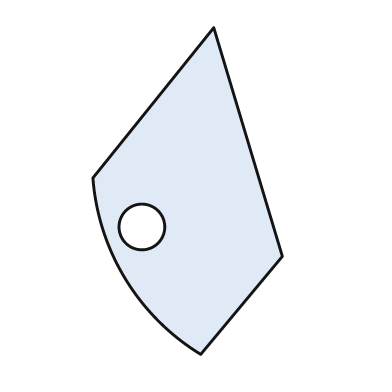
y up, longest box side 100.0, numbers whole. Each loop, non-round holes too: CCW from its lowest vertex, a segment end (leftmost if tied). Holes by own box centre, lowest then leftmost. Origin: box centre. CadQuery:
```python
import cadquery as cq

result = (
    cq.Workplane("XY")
    .moveTo(4.0, -50.0)
    .lineTo(29.0, -20.0)
    .lineTo(8.0, 50.0)
    .lineTo(-29.0, 4.0)
    .threePointArc((-19.0, -27.0), (4.0, -50.0))
    .close()
    .moveTo(-14.0, -11.0)
    .circle(7.0)
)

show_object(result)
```